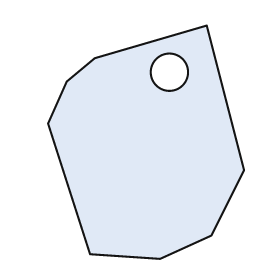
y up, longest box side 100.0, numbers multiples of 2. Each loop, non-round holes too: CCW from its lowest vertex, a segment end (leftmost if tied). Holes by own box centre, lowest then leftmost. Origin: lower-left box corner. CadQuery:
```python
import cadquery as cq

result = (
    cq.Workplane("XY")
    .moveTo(48.0, 0.0)
    .lineTo(70.0, 10.0)
    .lineTo(84.0, 38.0)
    .lineTo(68.0, 100.0)
    .lineTo(20.0, 86.0)
    .lineTo(8.0, 76.0)
    .lineTo(0.0, 58.0)
    .lineTo(18.0, 2.0)
    .close()
    .moveTo(52.0, 80.0)
    .circle(8.0)
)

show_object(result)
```